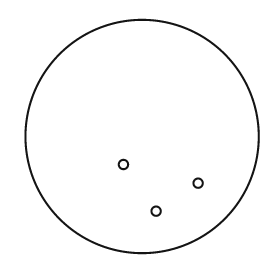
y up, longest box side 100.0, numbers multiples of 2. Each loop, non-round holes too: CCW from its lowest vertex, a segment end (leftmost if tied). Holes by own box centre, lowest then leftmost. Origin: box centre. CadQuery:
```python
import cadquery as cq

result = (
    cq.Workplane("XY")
    .moveTo(0.0, 0.0)
    .circle(50.0)
    .moveTo(6.0, -32.0)
    .circle(2.0)
    .moveTo(24.0, -20.0)
    .circle(2.0)
    .moveTo(-8.0, -12.0)
    .circle(2.0)
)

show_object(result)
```